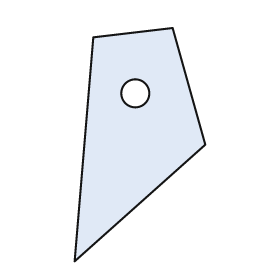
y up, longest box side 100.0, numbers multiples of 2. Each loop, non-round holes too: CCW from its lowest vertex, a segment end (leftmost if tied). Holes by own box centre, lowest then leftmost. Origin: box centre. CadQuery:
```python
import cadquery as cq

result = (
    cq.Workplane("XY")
    .moveTo(-28.0, -50.0)
    .lineTo(28.0, 0.0)
    .lineTo(14.0, 50.0)
    .lineTo(-20.0, 46.0)
    .close()
    .moveTo(-2.0, 22.0)
    .circle(6.0)
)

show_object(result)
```